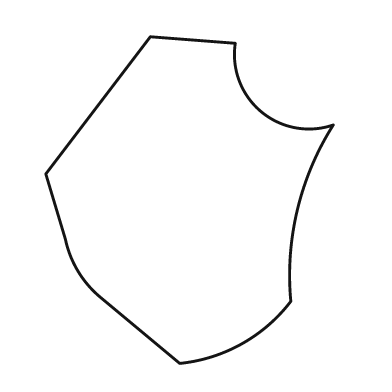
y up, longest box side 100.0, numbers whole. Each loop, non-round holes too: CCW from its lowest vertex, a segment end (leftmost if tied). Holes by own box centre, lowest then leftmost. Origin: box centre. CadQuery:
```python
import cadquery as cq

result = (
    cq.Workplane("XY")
    .moveTo(-3.0, -50.0)
    .threePointArc((16.0, -44.0), (31.0, -31.0))
    .threePointArc((33.0, -3.0), (44.0, 23.0))
    .threePointArc((22.0, 27.0), (14.0, 48.0))
    .lineTo(-12.0, 50.0)
    .lineTo(-44.0, 8.0)
    .lineTo(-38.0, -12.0)
    .threePointArc((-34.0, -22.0), (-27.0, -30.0))
    .close()
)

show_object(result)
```